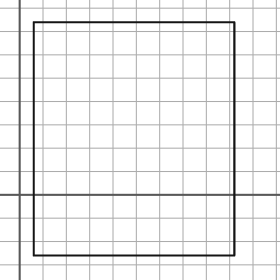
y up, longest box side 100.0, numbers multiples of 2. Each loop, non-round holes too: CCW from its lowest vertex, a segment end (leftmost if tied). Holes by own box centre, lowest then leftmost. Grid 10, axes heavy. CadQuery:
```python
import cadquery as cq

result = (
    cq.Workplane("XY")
    .moveTo(6.0, -26.0)
    .lineTo(92.0, -26.0)
    .lineTo(92.0, 74.0)
    .lineTo(6.0, 74.0)
    .close()
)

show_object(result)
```